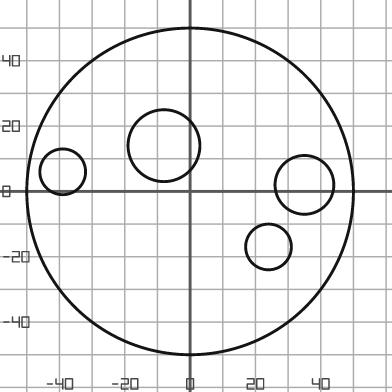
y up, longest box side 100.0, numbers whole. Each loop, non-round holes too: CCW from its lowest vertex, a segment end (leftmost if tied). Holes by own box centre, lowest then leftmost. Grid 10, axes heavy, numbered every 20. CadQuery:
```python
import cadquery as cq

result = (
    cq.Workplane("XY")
    .moveTo(0.0, 0.0)
    .circle(50.0)
    .moveTo(24.0, -17.0)
    .circle(7.0)
    .moveTo(35.0, 2.0)
    .circle(9.0)
    .moveTo(-39.0, 6.0)
    .circle(7.0)
    .moveTo(-8.0, 14.0)
    .circle(11.0)
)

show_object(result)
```